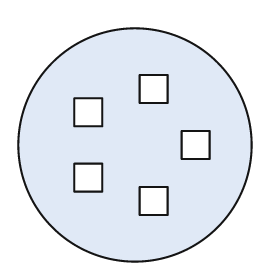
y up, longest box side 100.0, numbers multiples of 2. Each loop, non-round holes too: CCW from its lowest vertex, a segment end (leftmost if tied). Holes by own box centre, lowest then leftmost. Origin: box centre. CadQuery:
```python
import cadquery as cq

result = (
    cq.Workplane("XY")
    .moveTo(0.0, 0.0)
    .circle(50.0)
    .moveTo(2.0, -30.0)
    .lineTo(14.0, -30.0)
    .lineTo(14.0, -18.0)
    .lineTo(2.0, -18.0)
    .close()
    .moveTo(-26.0, -20.0)
    .lineTo(-14.0, -20.0)
    .lineTo(-14.0, -8.0)
    .lineTo(-26.0, -8.0)
    .close()
    .moveTo(20.0, -6.0)
    .lineTo(32.0, -6.0)
    .lineTo(32.0, 6.0)
    .lineTo(20.0, 6.0)
    .close()
    .moveTo(-26.0, 8.0)
    .lineTo(-14.0, 8.0)
    .lineTo(-14.0, 20.0)
    .lineTo(-26.0, 20.0)
    .close()
    .moveTo(2.0, 18.0)
    .lineTo(14.0, 18.0)
    .lineTo(14.0, 30.0)
    .lineTo(2.0, 30.0)
    .close()
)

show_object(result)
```